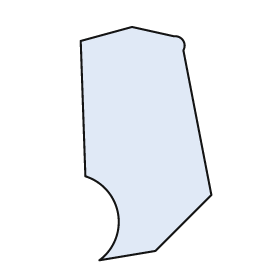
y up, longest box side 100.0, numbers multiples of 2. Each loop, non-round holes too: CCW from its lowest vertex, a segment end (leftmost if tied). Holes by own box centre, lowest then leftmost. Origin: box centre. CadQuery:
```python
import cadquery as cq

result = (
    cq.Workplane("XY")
    .moveTo(-20.0, -50.0)
    .lineTo(4.0, -46.0)
    .lineTo(28.0, -22.0)
    .lineTo(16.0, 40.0)
    .threePointArc((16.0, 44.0), (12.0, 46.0))
    .lineTo(-6.0, 50.0)
    .lineTo(-28.0, 44.0)
    .lineTo(-26.0, -14.0)
    .threePointArc((-12.0, -30.0), (-20.0, -50.0))
    .close()
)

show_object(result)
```